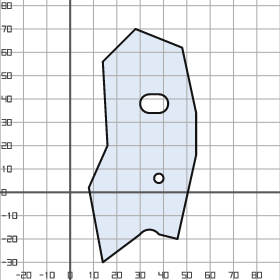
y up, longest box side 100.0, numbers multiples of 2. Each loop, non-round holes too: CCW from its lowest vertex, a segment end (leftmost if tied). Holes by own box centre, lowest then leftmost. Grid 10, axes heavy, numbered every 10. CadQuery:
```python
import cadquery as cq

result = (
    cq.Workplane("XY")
    .moveTo(14.0, -30.0)
    .lineTo(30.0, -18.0)
    .threePointArc((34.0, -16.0), (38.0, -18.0))
    .lineTo(46.0, -20.0)
    .lineTo(54.0, 16.0)
    .lineTo(54.0, 34.0)
    .lineTo(48.0, 62.0)
    .lineTo(28.0, 70.0)
    .lineTo(14.0, 56.0)
    .lineTo(16.0, 20.0)
    .lineTo(8.0, 2.0)
    .close()
    .moveTo(38.0, 6.0)
    .circle(2.0)
    .moveTo(34.0, 34.0)
    .lineTo(38.0, 34.0)
    .threePointArc((42.0, 38.0), (38.0, 42.0))
    .lineTo(34.0, 42.0)
    .threePointArc((30.0, 38.0), (34.0, 34.0))
    .close()
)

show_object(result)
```